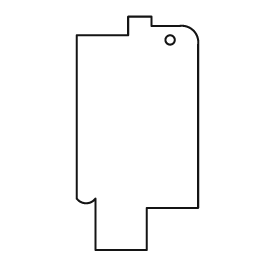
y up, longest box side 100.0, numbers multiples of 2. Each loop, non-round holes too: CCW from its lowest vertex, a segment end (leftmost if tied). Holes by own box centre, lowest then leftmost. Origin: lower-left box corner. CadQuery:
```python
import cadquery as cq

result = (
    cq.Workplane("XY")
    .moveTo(8.0, 0.0)
    .lineTo(30.0, 0.0)
    .lineTo(30.0, 18.0)
    .lineTo(52.0, 18.0)
    .lineTo(52.0, 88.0)
    .threePointArc((50.0, 94.0), (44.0, 96.0))
    .lineTo(32.0, 96.0)
    .lineTo(32.0, 100.0)
    .lineTo(22.0, 100.0)
    .lineTo(22.0, 92.0)
    .lineTo(0.0, 92.0)
    .lineTo(0.0, 22.0)
    .threePointArc((4.0, 20.0), (8.0, 22.0))
    .close()
    .moveTo(40.0, 90.0)
    .circle(2.0)
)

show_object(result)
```